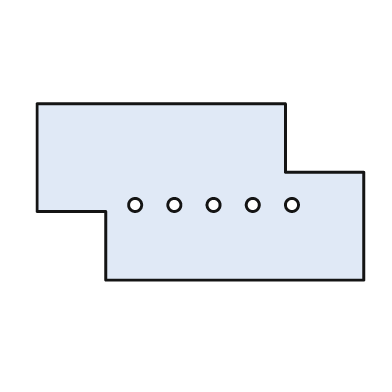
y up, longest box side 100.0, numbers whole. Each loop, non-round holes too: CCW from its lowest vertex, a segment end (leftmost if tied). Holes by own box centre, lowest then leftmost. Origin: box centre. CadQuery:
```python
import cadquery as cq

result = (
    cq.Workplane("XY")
    .moveTo(-29.0, -27.0)
    .lineTo(50.0, -27.0)
    .lineTo(50.0, 6.0)
    .lineTo(26.0, 6.0)
    .lineTo(26.0, 27.0)
    .lineTo(-50.0, 27.0)
    .lineTo(-50.0, -6.0)
    .lineTo(-29.0, -6.0)
    .close()
    .moveTo(-20.0, -4.0)
    .circle(2.0)
    .moveTo(-8.0, -4.0)
    .circle(2.0)
    .moveTo(4.0, -4.0)
    .circle(2.0)
    .moveTo(16.0, -4.0)
    .circle(2.0)
    .moveTo(28.0, -4.0)
    .circle(2.0)
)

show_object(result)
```